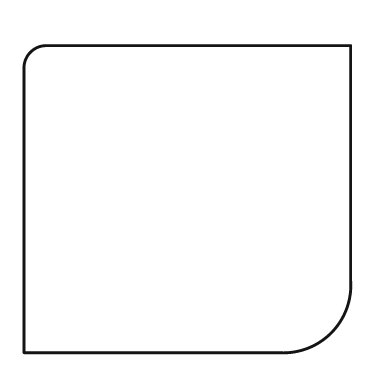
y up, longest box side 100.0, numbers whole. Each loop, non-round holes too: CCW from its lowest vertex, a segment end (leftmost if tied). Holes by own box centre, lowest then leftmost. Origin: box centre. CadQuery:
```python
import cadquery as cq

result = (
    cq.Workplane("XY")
    .moveTo(-50.0, -47.0)
    .lineTo(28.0, -47.0)
    .threePointArc((44.0, -41.0), (50.0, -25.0))
    .lineTo(50.0, 47.0)
    .lineTo(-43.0, 47.0)
    .threePointArc((-48.0, 45.0), (-50.0, 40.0))
    .close()
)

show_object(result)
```